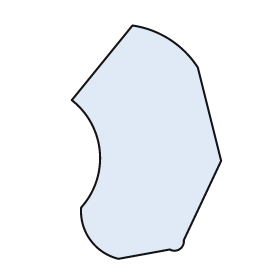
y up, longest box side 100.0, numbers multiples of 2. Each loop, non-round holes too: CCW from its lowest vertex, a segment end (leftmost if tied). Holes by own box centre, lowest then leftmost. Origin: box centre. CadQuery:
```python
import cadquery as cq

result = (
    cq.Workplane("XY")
    .moveTo(-12.0, -50.0)
    .lineTo(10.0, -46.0)
    .threePointArc((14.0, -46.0), (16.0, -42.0))
    .lineTo(32.0, -8.0)
    .lineTo(22.0, 32.0)
    .threePointArc((10.0, 44.0), (-6.0, 50.0))
    .lineTo(-32.0, 18.0)
    .threePointArc((-20.0, -4.0), (-28.0, -28.0))
    .threePointArc((-24.0, -42.0), (-12.0, -50.0))
    .close()
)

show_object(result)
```